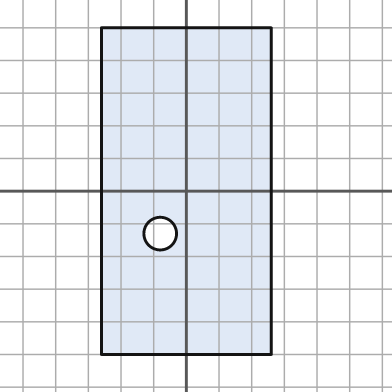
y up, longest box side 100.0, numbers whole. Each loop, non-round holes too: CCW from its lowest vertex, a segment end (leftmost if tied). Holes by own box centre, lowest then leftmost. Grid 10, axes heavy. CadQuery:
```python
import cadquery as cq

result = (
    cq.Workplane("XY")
    .moveTo(-26.0, -50.0)
    .lineTo(26.0, -50.0)
    .lineTo(26.0, 50.0)
    .lineTo(-26.0, 50.0)
    .close()
    .moveTo(-8.0, -13.0)
    .circle(5.0)
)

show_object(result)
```